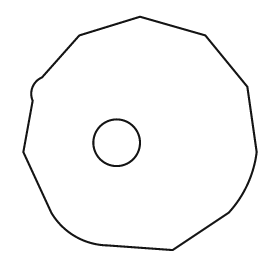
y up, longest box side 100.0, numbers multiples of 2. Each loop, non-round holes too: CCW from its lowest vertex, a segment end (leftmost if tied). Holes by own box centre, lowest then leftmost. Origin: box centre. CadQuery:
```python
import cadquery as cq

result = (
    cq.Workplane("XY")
    .moveTo(14.0, -50.0)
    .lineTo(38.0, -34.0)
    .threePointArc((46.0, -22.0), (50.0, -8.0))
    .lineTo(46.0, 20.0)
    .lineTo(28.0, 42.0)
    .lineTo(0.0, 50.0)
    .lineTo(-26.0, 42.0)
    .lineTo(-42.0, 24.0)
    .threePointArc((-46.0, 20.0), (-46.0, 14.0))
    .lineTo(-50.0, -8.0)
    .lineTo(-38.0, -34.0)
    .threePointArc((-28.0, -44.0), (-14.0, -48.0))
    .close()
    .moveTo(-10.0, -4.0)
    .circle(10.0)
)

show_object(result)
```